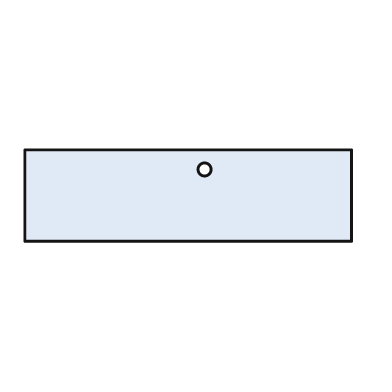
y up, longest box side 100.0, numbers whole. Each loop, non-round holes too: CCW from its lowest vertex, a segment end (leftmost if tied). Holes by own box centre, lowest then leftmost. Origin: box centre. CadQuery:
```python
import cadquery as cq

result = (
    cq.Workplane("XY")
    .moveTo(-50.0, -14.0)
    .lineTo(50.0, -14.0)
    .lineTo(50.0, 14.0)
    .lineTo(-50.0, 14.0)
    .close()
    .moveTo(5.0, 8.0)
    .circle(2.0)
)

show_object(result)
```